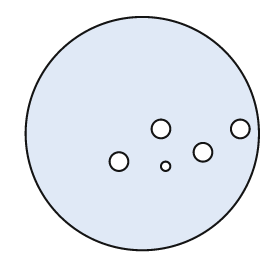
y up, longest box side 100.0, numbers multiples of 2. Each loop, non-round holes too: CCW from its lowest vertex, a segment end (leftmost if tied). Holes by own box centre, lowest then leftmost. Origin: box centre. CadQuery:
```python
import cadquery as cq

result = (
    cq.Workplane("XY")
    .moveTo(0.0, 0.0)
    .circle(50.0)
    .moveTo(10.0, -14.0)
    .circle(2.0)
    .moveTo(-10.0, -12.0)
    .circle(4.0)
    .moveTo(26.0, -8.0)
    .circle(4.0)
    .moveTo(8.0, 2.0)
    .circle(4.0)
    .moveTo(42.0, 2.0)
    .circle(4.0)
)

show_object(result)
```